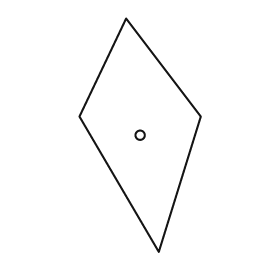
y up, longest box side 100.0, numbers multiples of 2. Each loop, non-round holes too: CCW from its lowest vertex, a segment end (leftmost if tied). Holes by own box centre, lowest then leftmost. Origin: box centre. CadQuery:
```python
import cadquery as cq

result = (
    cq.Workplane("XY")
    .moveTo(8.0, -50.0)
    .lineTo(26.0, 8.0)
    .lineTo(-6.0, 50.0)
    .lineTo(-26.0, 8.0)
    .close()
    .moveTo(0.0, 0.0)
    .circle(2.0)
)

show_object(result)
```